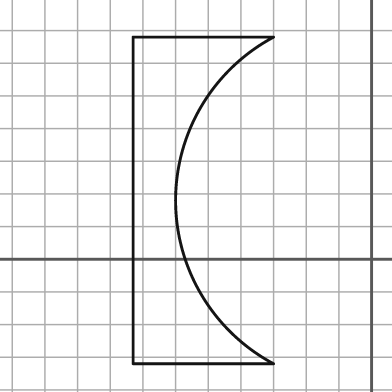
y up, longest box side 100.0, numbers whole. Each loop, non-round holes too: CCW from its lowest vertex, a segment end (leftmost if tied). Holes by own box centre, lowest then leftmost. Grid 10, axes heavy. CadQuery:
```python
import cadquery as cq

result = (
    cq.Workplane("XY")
    .moveTo(-73.0, -32.0)
    .lineTo(-30.0, -32.0)
    .threePointArc((-60.0, 18.0), (-30.0, 68.0))
    .lineTo(-73.0, 68.0)
    .close()
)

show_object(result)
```